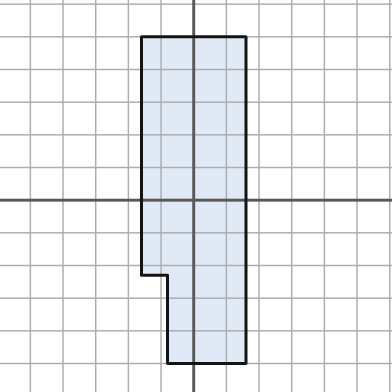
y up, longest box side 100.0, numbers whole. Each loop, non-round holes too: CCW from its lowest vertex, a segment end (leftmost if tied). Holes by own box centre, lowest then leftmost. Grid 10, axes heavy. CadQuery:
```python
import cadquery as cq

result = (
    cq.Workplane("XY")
    .moveTo(-8.0, -50.0)
    .lineTo(16.0, -50.0)
    .lineTo(16.0, 50.0)
    .lineTo(-16.0, 50.0)
    .lineTo(-16.0, -23.0)
    .lineTo(-8.0, -23.0)
    .close()
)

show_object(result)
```